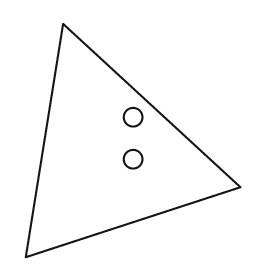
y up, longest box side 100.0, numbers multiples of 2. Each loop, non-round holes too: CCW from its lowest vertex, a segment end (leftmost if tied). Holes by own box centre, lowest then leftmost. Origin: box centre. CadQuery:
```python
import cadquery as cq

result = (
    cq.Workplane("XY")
    .moveTo(-46.0, -50.0)
    .lineTo(46.0, -20.0)
    .lineTo(-30.0, 50.0)
    .close()
    .moveTo(0.0, -8.0)
    .circle(4.0)
    .moveTo(0.0, 10.0)
    .circle(4.0)
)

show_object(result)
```